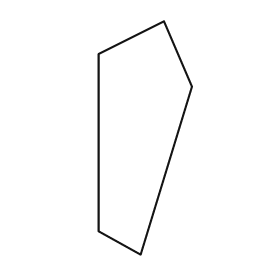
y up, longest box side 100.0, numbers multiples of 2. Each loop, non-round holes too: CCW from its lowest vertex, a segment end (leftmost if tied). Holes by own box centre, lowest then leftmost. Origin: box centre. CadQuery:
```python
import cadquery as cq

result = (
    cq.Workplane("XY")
    .moveTo(-2.0, -50.0)
    .lineTo(20.0, 22.0)
    .lineTo(8.0, 50.0)
    .lineTo(-20.0, 36.0)
    .lineTo(-20.0, -40.0)
    .close()
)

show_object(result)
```